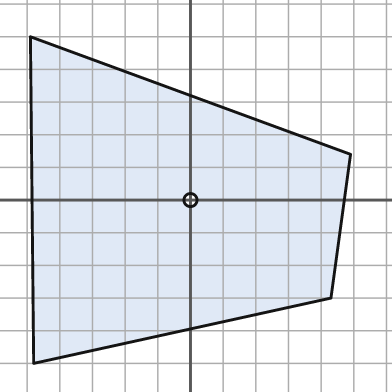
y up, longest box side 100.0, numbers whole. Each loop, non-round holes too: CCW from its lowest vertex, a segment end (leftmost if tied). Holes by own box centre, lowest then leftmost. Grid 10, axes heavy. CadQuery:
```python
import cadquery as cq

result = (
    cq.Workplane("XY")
    .moveTo(-48.0, -50.0)
    .lineTo(43.0, -30.0)
    .lineTo(49.0, 14.0)
    .lineTo(-49.0, 50.0)
    .close()
    .moveTo(0.0, 0.0)
    .circle(2.0)
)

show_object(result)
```